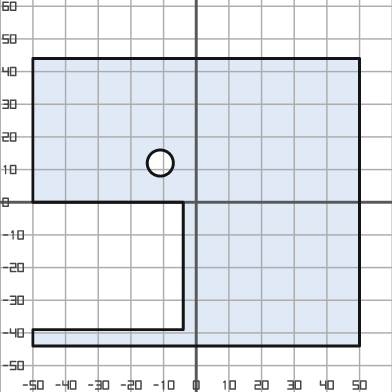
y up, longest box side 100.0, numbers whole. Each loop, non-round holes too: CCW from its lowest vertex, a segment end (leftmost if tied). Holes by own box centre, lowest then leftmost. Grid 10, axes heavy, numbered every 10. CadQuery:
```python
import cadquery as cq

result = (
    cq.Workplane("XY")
    .moveTo(-50.0, -44.0)
    .lineTo(50.0, -44.0)
    .lineTo(50.0, 44.0)
    .lineTo(-50.0, 44.0)
    .lineTo(-50.0, 0.0)
    .lineTo(-4.0, 0.0)
    .lineTo(-4.0, -39.0)
    .lineTo(-50.0, -39.0)
    .close()
    .moveTo(-11.0, 12.0)
    .circle(4.0)
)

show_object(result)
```